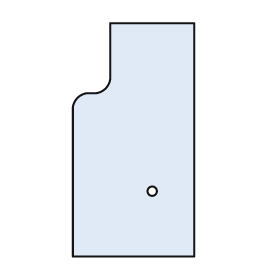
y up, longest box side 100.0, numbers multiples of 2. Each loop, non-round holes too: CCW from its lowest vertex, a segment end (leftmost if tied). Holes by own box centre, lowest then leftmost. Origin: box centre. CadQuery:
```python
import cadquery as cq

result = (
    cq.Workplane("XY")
    .moveTo(-26.0, -50.0)
    .lineTo(26.0, -50.0)
    .lineTo(26.0, 50.0)
    .lineTo(-10.0, 50.0)
    .lineTo(-10.0, 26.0)
    .threePointArc((-12.0, 22.0), (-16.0, 20.0))
    .lineTo(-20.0, 20.0)
    .threePointArc((-24.0, 18.0), (-26.0, 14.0))
    .close()
    .moveTo(8.0, -22.0)
    .circle(2.0)
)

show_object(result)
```